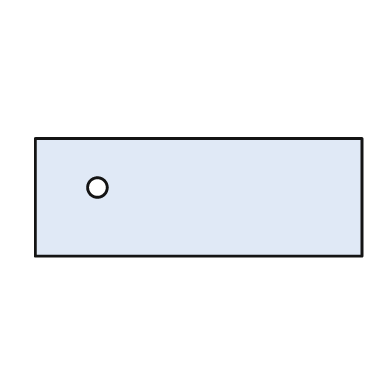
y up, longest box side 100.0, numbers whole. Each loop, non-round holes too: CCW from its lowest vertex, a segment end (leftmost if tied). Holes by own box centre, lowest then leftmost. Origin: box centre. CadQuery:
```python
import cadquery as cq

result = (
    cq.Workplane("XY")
    .moveTo(-50.0, -18.0)
    .lineTo(50.0, -18.0)
    .lineTo(50.0, 18.0)
    .lineTo(-50.0, 18.0)
    .close()
    .moveTo(-31.0, 3.0)
    .circle(3.0)
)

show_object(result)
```